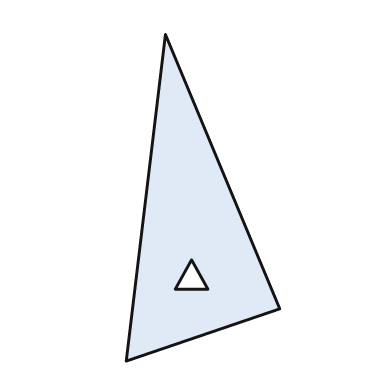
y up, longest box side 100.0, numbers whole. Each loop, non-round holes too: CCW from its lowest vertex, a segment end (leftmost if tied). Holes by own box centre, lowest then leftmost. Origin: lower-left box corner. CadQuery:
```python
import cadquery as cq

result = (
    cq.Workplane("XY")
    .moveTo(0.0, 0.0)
    .lineTo(47.0, 16.0)
    .lineTo(12.0, 100.0)
    .close()
    .moveTo(15.0, 22.0)
    .lineTo(25.0, 22.0)
    .lineTo(20.0, 31.0)
    .close()
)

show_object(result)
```